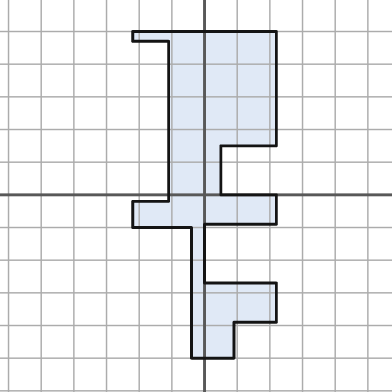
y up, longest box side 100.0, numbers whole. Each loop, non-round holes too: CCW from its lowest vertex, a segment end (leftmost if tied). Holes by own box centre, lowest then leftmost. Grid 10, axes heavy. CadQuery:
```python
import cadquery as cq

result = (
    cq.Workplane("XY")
    .moveTo(-4.0, -50.0)
    .lineTo(9.0, -50.0)
    .lineTo(9.0, -39.0)
    .lineTo(22.0, -39.0)
    .lineTo(22.0, -27.0)
    .lineTo(0.0, -27.0)
    .lineTo(0.0, -9.0)
    .lineTo(22.0, -9.0)
    .lineTo(22.0, 0.0)
    .lineTo(5.0, 0.0)
    .lineTo(5.0, 15.0)
    .lineTo(22.0, 15.0)
    .lineTo(22.0, 50.0)
    .lineTo(-22.0, 50.0)
    .lineTo(-22.0, 47.0)
    .lineTo(-11.0, 47.0)
    .lineTo(-11.0, -2.0)
    .lineTo(-22.0, -2.0)
    .lineTo(-22.0, -10.0)
    .lineTo(-4.0, -10.0)
    .close()
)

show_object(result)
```